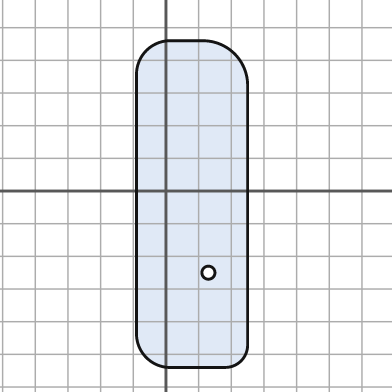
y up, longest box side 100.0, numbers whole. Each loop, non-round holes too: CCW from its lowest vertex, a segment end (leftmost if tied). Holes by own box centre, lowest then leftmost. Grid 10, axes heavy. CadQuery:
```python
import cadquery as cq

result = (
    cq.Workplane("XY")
    .moveTo(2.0, -54.0)
    .lineTo(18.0, -54.0)
    .threePointArc((23.0, -52.0), (25.0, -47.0))
    .lineTo(25.0, 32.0)
    .threePointArc((21.0, 42.0), (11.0, 46.0))
    .lineTo(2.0, 46.0)
    .threePointArc((-6.0, 43.0), (-9.0, 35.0))
    .lineTo(-9.0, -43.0)
    .threePointArc((-6.0, -51.0), (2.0, -54.0))
    .close()
    .moveTo(13.0, -25.0)
    .circle(2.0)
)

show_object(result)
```